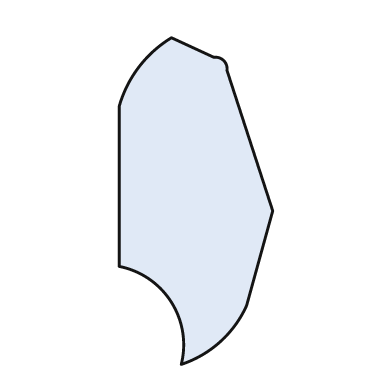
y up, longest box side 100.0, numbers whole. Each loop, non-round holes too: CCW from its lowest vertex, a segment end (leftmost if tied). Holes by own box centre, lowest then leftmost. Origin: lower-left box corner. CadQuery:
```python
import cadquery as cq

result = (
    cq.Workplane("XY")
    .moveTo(19.0, 0.0)
    .threePointArc((31.0, 7.0), (39.0, 18.0))
    .lineTo(47.0, 47.0)
    .lineTo(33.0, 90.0)
    .threePointArc((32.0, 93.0), (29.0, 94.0))
    .lineTo(16.0, 100.0)
    .threePointArc((6.0, 91.0), (0.0, 79.0))
    .lineTo(0.0, 30.0)
    .threePointArc((16.0, 19.0), (19.0, 0.0))
    .close()
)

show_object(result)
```